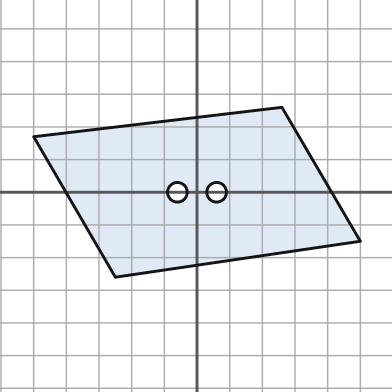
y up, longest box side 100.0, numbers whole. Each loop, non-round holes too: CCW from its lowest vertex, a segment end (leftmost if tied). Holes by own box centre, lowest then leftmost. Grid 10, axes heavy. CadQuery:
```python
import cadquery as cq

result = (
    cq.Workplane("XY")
    .moveTo(-25.0, -26.0)
    .lineTo(50.0, -15.0)
    .lineTo(26.0, 26.0)
    .lineTo(-50.0, 17.0)
    .close()
    .moveTo(-6.0, 0.0)
    .circle(3.0)
    .moveTo(6.0, 0.0)
    .circle(3.0)
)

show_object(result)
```